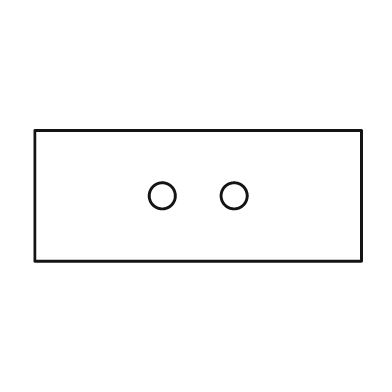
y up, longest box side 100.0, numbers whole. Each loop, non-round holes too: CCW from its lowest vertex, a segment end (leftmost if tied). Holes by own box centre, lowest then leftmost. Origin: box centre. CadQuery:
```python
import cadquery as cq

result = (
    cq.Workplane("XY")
    .moveTo(-50.0, -20.0)
    .lineTo(50.0, -20.0)
    .lineTo(50.0, 20.0)
    .lineTo(-50.0, 20.0)
    .close()
    .moveTo(-11.0, 0.0)
    .circle(4.0)
    .moveTo(11.0, 0.0)
    .circle(4.0)
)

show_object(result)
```